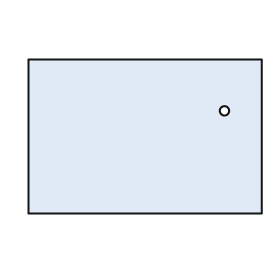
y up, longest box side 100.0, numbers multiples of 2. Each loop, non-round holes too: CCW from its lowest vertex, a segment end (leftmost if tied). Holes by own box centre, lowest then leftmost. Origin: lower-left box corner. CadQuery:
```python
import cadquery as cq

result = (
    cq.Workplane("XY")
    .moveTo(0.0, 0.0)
    .lineTo(100.0, 0.0)
    .lineTo(100.0, 66.0)
    .lineTo(0.0, 66.0)
    .close()
    .moveTo(84.0, 44.0)
    .circle(2.0)
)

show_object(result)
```